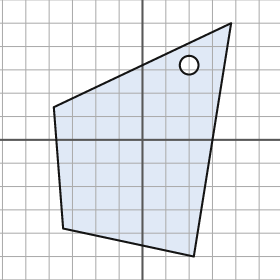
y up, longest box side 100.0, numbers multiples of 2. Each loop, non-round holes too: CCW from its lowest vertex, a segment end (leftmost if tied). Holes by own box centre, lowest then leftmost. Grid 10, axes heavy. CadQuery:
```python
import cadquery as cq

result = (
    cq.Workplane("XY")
    .moveTo(22.0, -50.0)
    .lineTo(38.0, 50.0)
    .lineTo(-38.0, 14.0)
    .lineTo(-34.0, -38.0)
    .close()
    .moveTo(20.0, 32.0)
    .circle(4.0)
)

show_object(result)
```